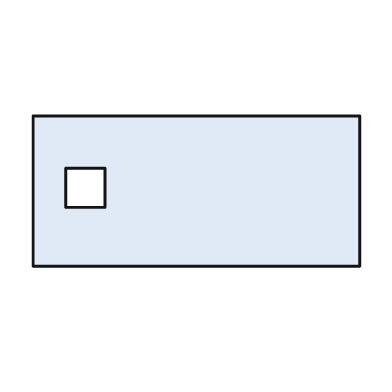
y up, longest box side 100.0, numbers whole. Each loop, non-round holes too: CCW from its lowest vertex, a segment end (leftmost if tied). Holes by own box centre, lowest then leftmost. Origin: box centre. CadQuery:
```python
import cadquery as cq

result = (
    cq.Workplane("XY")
    .moveTo(-50.0, -23.0)
    .lineTo(50.0, -23.0)
    .lineTo(50.0, 23.0)
    .lineTo(-50.0, 23.0)
    .close()
    .moveTo(-40.0, -5.0)
    .lineTo(-28.0, -5.0)
    .lineTo(-28.0, 7.0)
    .lineTo(-40.0, 7.0)
    .close()
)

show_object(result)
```